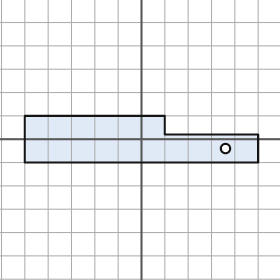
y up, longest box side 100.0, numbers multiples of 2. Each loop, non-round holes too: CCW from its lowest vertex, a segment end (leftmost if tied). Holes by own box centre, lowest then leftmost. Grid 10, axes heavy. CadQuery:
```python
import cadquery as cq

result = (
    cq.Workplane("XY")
    .moveTo(-50.0, -10.0)
    .lineTo(50.0, -10.0)
    .lineTo(50.0, 2.0)
    .lineTo(10.0, 2.0)
    .lineTo(10.0, 10.0)
    .lineTo(-50.0, 10.0)
    .close()
    .moveTo(36.0, -4.0)
    .circle(2.0)
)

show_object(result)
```